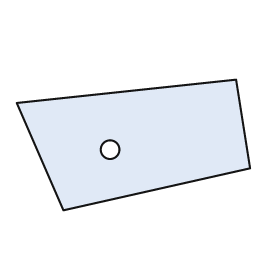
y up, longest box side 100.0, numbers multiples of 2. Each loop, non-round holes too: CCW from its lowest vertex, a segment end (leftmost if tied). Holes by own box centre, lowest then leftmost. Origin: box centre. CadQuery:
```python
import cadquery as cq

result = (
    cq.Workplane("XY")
    .moveTo(-30.0, -28.0)
    .lineTo(50.0, -10.0)
    .lineTo(44.0, 28.0)
    .lineTo(-50.0, 18.0)
    .close()
    .moveTo(-10.0, -2.0)
    .circle(4.0)
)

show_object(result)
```